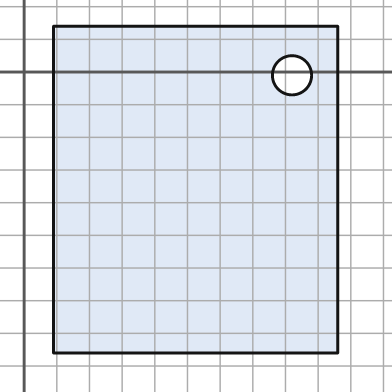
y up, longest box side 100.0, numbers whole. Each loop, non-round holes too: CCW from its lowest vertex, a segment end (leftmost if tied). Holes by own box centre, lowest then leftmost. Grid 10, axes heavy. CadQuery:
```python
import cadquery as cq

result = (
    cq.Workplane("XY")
    .moveTo(9.0, -86.0)
    .lineTo(96.0, -86.0)
    .lineTo(96.0, 14.0)
    .lineTo(9.0, 14.0)
    .close()
    .moveTo(82.0, -1.0)
    .circle(6.0)
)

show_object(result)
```